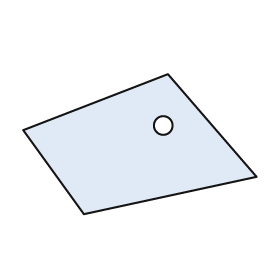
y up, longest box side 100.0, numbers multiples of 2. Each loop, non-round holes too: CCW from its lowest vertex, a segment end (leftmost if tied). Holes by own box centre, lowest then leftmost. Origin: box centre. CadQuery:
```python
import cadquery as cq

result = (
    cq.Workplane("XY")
    .moveTo(-24.0, -30.0)
    .lineTo(50.0, -14.0)
    .lineTo(12.0, 30.0)
    .lineTo(-50.0, 6.0)
    .close()
    .moveTo(10.0, 8.0)
    .circle(4.0)
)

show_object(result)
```